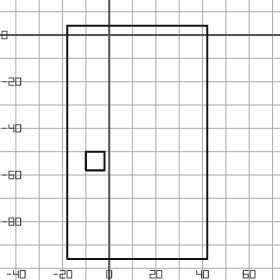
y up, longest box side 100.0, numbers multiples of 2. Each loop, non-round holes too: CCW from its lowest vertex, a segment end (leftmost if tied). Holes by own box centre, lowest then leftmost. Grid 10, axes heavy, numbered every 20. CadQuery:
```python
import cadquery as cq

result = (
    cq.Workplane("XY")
    .moveTo(-18.0, -96.0)
    .lineTo(42.0, -96.0)
    .lineTo(42.0, 4.0)
    .lineTo(-18.0, 4.0)
    .close()
    .moveTo(-10.0, -58.0)
    .lineTo(-2.0, -58.0)
    .lineTo(-2.0, -50.0)
    .lineTo(-10.0, -50.0)
    .close()
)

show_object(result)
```